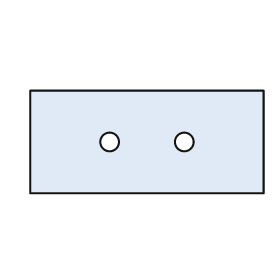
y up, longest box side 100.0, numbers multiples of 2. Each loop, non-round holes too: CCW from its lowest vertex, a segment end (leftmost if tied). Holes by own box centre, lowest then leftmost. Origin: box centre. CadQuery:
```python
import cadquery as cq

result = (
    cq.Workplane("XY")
    .moveTo(-50.0, -22.0)
    .lineTo(50.0, -22.0)
    .lineTo(50.0, 22.0)
    .lineTo(-50.0, 22.0)
    .close()
    .moveTo(-16.0, 0.0)
    .circle(4.0)
    .moveTo(16.0, 0.0)
    .circle(4.0)
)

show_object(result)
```